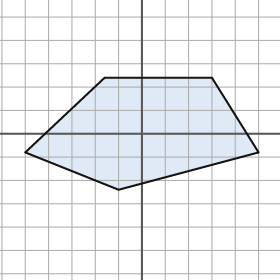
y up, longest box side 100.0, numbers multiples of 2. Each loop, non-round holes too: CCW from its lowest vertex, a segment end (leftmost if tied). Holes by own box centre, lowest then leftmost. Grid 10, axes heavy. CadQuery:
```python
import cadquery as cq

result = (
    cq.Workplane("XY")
    .moveTo(-10.0, -24.0)
    .lineTo(50.0, -8.0)
    .lineTo(30.0, 24.0)
    .lineTo(-16.0, 24.0)
    .lineTo(-50.0, -8.0)
    .close()
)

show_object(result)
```